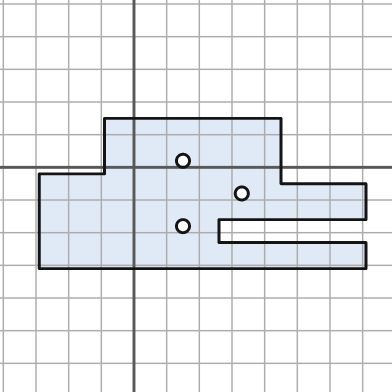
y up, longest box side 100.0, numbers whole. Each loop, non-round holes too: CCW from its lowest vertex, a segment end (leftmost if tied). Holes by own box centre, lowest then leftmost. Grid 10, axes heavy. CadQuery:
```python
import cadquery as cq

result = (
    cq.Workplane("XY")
    .moveTo(-29.0, -31.0)
    .lineTo(71.0, -31.0)
    .lineTo(71.0, -23.0)
    .lineTo(26.0, -23.0)
    .lineTo(26.0, -16.0)
    .lineTo(71.0, -16.0)
    .lineTo(71.0, -5.0)
    .lineTo(45.0, -5.0)
    .lineTo(45.0, 15.0)
    .lineTo(-9.0, 15.0)
    .lineTo(-9.0, -2.0)
    .lineTo(-29.0, -2.0)
    .close()
    .moveTo(15.0, -18.0)
    .circle(2.0)
    .moveTo(33.0, -8.0)
    .circle(2.0)
    .moveTo(15.0, 2.0)
    .circle(2.0)
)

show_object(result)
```